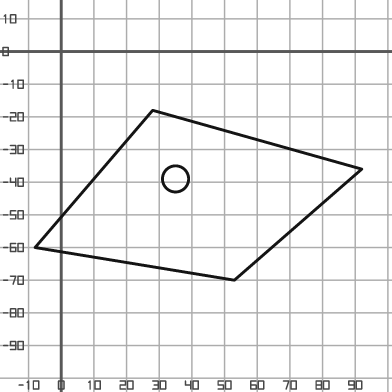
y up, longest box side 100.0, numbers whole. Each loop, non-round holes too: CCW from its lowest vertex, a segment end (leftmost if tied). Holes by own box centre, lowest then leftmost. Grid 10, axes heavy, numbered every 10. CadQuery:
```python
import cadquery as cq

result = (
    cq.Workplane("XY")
    .moveTo(53.0, -70.0)
    .lineTo(92.0, -36.0)
    .lineTo(28.0, -18.0)
    .lineTo(-8.0, -60.0)
    .close()
    .moveTo(35.0, -39.0)
    .circle(4.0)
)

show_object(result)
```